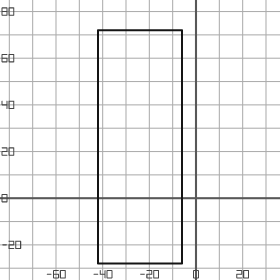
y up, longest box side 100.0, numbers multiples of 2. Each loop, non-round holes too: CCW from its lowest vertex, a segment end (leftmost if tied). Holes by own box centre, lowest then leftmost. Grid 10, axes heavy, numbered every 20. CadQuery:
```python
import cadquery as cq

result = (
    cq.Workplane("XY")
    .moveTo(-42.0, -28.0)
    .lineTo(-6.0, -28.0)
    .lineTo(-6.0, 72.0)
    .lineTo(-42.0, 72.0)
    .close()
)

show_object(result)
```